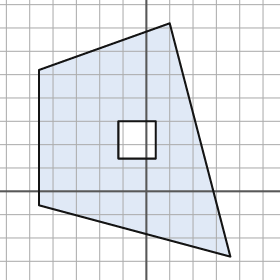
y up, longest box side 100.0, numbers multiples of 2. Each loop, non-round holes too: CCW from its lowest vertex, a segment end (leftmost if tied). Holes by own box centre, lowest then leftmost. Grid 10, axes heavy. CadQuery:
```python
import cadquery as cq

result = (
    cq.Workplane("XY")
    .moveTo(36.0, -28.0)
    .lineTo(10.0, 72.0)
    .lineTo(-46.0, 52.0)
    .lineTo(-46.0, -6.0)
    .close()
    .moveTo(-12.0, 14.0)
    .lineTo(4.0, 14.0)
    .lineTo(4.0, 30.0)
    .lineTo(-12.0, 30.0)
    .close()
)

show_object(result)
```